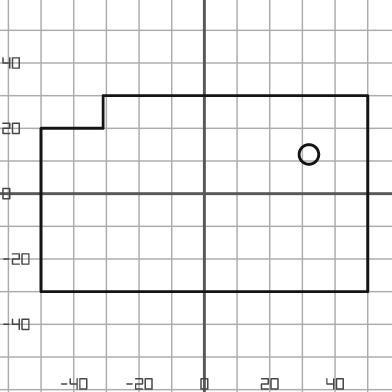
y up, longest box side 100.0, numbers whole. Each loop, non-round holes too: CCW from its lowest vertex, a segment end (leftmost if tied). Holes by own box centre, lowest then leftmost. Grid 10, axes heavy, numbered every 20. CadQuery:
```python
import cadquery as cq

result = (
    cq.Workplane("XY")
    .moveTo(-50.0, -30.0)
    .lineTo(50.0, -30.0)
    .lineTo(50.0, 30.0)
    .lineTo(-31.0, 30.0)
    .lineTo(-31.0, 20.0)
    .lineTo(-50.0, 20.0)
    .close()
    .moveTo(32.0, 12.0)
    .circle(3.0)
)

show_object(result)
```